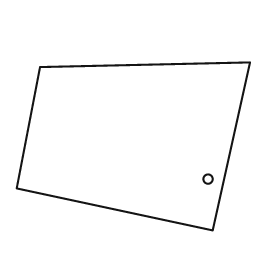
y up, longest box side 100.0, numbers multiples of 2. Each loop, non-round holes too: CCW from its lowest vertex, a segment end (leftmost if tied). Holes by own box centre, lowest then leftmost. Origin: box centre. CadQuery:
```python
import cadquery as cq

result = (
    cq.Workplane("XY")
    .moveTo(34.0, -36.0)
    .lineTo(50.0, 36.0)
    .lineTo(-40.0, 34.0)
    .lineTo(-50.0, -18.0)
    .close()
    .moveTo(32.0, -14.0)
    .circle(2.0)
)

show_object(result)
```